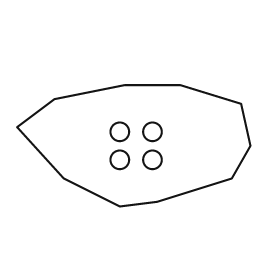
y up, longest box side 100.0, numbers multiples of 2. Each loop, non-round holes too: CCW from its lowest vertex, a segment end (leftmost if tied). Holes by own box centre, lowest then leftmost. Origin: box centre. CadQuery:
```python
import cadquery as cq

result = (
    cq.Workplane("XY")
    .moveTo(-6.0, -26.0)
    .lineTo(10.0, -24.0)
    .lineTo(42.0, -14.0)
    .lineTo(50.0, 0.0)
    .lineTo(46.0, 18.0)
    .lineTo(20.0, 26.0)
    .lineTo(-4.0, 26.0)
    .lineTo(-34.0, 20.0)
    .lineTo(-50.0, 8.0)
    .lineTo(-30.0, -14.0)
    .close()
    .moveTo(-6.0, -6.0)
    .circle(4.0)
    .moveTo(8.0, -6.0)
    .circle(4.0)
    .moveTo(-6.0, 6.0)
    .circle(4.0)
    .moveTo(8.0, 6.0)
    .circle(4.0)
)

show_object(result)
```